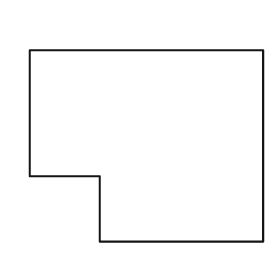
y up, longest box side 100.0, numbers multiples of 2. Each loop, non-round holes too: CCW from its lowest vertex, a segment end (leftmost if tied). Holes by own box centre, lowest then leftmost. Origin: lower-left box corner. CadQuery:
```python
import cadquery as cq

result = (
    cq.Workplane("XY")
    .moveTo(30.0, 0.0)
    .lineTo(100.0, 0.0)
    .lineTo(100.0, 82.0)
    .lineTo(0.0, 82.0)
    .lineTo(0.0, 28.0)
    .lineTo(30.0, 28.0)
    .close()
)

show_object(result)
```